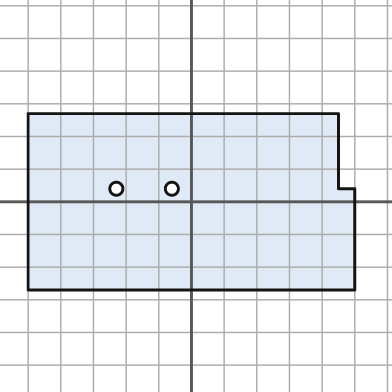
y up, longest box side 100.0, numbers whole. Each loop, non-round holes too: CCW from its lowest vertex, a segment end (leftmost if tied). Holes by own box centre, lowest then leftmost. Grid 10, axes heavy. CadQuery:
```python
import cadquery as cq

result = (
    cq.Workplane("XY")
    .moveTo(-50.0, -27.0)
    .lineTo(50.0, -27.0)
    .lineTo(50.0, 4.0)
    .lineTo(45.0, 4.0)
    .lineTo(45.0, 27.0)
    .lineTo(-50.0, 27.0)
    .close()
    .moveTo(-23.0, 4.0)
    .circle(2.0)
    .moveTo(-6.0, 4.0)
    .circle(2.0)
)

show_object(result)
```